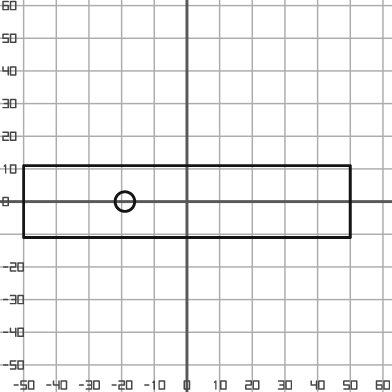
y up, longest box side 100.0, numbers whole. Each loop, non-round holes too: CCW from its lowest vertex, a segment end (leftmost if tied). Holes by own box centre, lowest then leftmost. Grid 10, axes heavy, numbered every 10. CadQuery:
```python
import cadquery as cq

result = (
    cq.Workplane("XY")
    .moveTo(-50.0, -11.0)
    .lineTo(50.0, -11.0)
    .lineTo(50.0, 11.0)
    .lineTo(-50.0, 11.0)
    .close()
    .moveTo(-19.0, 0.0)
    .circle(3.0)
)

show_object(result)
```